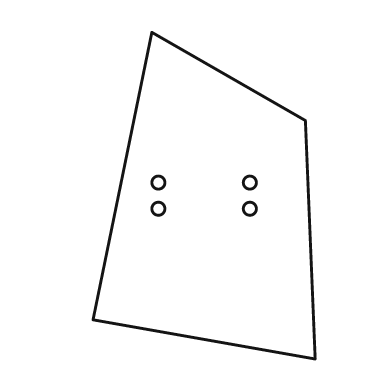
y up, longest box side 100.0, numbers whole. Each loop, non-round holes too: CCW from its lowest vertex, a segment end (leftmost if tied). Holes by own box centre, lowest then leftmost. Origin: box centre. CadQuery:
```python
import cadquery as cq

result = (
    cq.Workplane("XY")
    .moveTo(34.0, -50.0)
    .lineTo(31.0, 23.0)
    .lineTo(-16.0, 50.0)
    .lineTo(-34.0, -38.0)
    .close()
    .moveTo(-14.0, -4.0)
    .circle(2.0)
    .moveTo(14.0, -4.0)
    .circle(2.0)
    .moveTo(-14.0, 4.0)
    .circle(2.0)
    .moveTo(14.0, 4.0)
    .circle(2.0)
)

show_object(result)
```